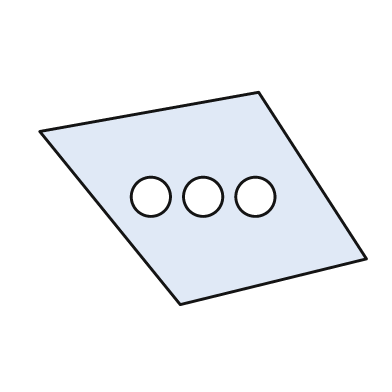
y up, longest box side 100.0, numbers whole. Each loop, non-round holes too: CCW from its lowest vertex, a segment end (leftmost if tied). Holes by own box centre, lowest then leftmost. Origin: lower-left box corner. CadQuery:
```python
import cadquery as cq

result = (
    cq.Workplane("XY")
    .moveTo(43.0, 0.0)
    .lineTo(100.0, 14.0)
    .lineTo(67.0, 65.0)
    .lineTo(0.0, 53.0)
    .close()
    .moveTo(34.0, 33.0)
    .circle(6.0)
    .moveTo(50.0, 33.0)
    .circle(6.0)
    .moveTo(66.0, 33.0)
    .circle(6.0)
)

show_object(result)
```